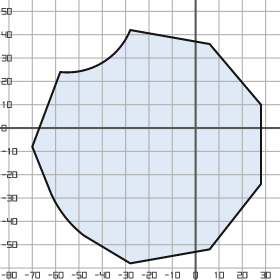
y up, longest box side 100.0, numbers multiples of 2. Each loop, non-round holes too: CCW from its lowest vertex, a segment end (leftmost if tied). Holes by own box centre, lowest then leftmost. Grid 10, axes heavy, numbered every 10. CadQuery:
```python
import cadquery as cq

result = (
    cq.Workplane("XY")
    .moveTo(-28.0, -58.0)
    .lineTo(6.0, -52.0)
    .lineTo(28.0, -24.0)
    .lineTo(28.0, 10.0)
    .lineTo(6.0, 36.0)
    .lineTo(-28.0, 42.0)
    .threePointArc((-40.0, 28.0), (-58.0, 24.0))
    .lineTo(-70.0, -8.0)
    .lineTo(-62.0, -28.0)
    .threePointArc((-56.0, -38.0), (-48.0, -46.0))
    .close()
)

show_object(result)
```